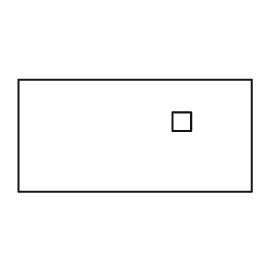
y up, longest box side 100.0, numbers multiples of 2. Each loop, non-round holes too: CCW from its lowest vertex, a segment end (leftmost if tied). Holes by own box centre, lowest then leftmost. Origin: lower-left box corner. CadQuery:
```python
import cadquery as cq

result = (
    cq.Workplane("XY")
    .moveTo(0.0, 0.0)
    .lineTo(100.0, 0.0)
    .lineTo(100.0, 48.0)
    .lineTo(0.0, 48.0)
    .close()
    .moveTo(66.0, 26.0)
    .lineTo(74.0, 26.0)
    .lineTo(74.0, 34.0)
    .lineTo(66.0, 34.0)
    .close()
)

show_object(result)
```